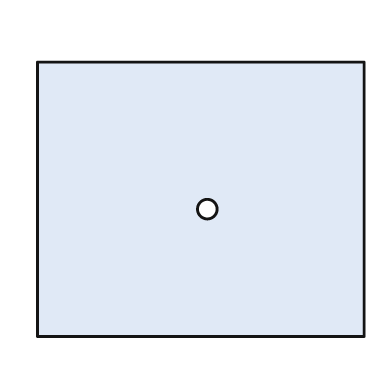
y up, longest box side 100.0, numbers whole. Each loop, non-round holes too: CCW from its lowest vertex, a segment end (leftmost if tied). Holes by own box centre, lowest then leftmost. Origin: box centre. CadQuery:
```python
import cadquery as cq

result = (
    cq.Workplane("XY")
    .moveTo(-50.0, -42.0)
    .lineTo(50.0, -42.0)
    .lineTo(50.0, 42.0)
    .lineTo(-50.0, 42.0)
    .close()
    .moveTo(2.0, -3.0)
    .circle(3.0)
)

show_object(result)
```